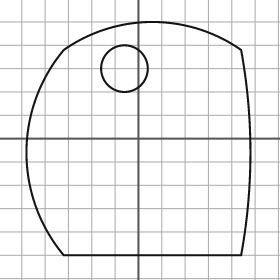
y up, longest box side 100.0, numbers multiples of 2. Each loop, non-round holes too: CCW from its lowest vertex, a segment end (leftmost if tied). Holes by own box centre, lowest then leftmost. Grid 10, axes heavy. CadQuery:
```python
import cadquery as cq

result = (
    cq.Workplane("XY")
    .moveTo(-32.0, -50.0)
    .lineTo(44.0, -50.0)
    .threePointArc((48.0, -6.0), (44.0, 38.0))
    .threePointArc((6.0, 50.0), (-32.0, 38.0))
    .threePointArc((-48.0, -6.0), (-32.0, -50.0))
    .close()
    .moveTo(-6.0, 30.0)
    .circle(10.0)
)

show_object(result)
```